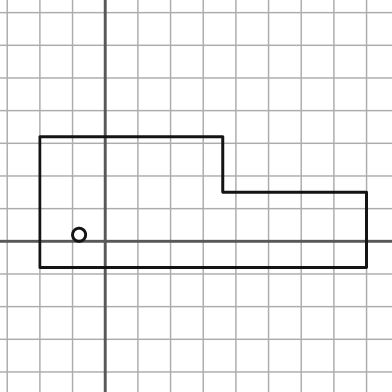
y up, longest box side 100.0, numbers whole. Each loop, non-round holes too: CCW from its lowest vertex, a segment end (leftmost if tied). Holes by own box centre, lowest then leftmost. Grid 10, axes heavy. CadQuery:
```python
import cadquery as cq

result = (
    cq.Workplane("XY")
    .moveTo(-20.0, -8.0)
    .lineTo(80.0, -8.0)
    .lineTo(80.0, 15.0)
    .lineTo(36.0, 15.0)
    .lineTo(36.0, 32.0)
    .lineTo(-20.0, 32.0)
    .close()
    .moveTo(-8.0, 2.0)
    .circle(2.0)
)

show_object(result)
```